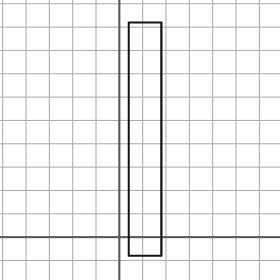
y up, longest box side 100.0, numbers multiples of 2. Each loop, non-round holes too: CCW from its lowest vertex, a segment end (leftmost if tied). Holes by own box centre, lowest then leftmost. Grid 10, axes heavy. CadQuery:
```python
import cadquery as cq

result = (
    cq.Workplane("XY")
    .moveTo(4.0, -8.0)
    .lineTo(18.0, -8.0)
    .lineTo(18.0, 92.0)
    .lineTo(4.0, 92.0)
    .close()
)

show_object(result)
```